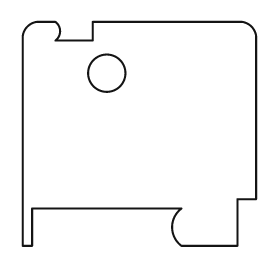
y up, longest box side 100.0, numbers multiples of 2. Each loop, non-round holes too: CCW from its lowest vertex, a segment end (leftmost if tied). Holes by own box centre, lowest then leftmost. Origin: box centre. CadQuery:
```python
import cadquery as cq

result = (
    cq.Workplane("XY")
    .moveTo(-50.0, -48.0)
    .lineTo(-46.0, -48.0)
    .lineTo(-46.0, -32.0)
    .lineTo(18.0, -32.0)
    .threePointArc((14.0, -40.0), (18.0, -48.0))
    .lineTo(42.0, -48.0)
    .lineTo(42.0, -28.0)
    .lineTo(50.0, -28.0)
    .lineTo(50.0, 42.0)
    .threePointArc((48.0, 46.0), (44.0, 48.0))
    .lineTo(-20.0, 48.0)
    .lineTo(-20.0, 40.0)
    .lineTo(-36.0, 40.0)
    .threePointArc((-34.0, 44.0), (-36.0, 48.0))
    .lineTo(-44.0, 48.0)
    .threePointArc((-48.0, 46.0), (-50.0, 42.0))
    .close()
    .moveTo(-14.0, 26.0)
    .circle(8.0)
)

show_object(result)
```